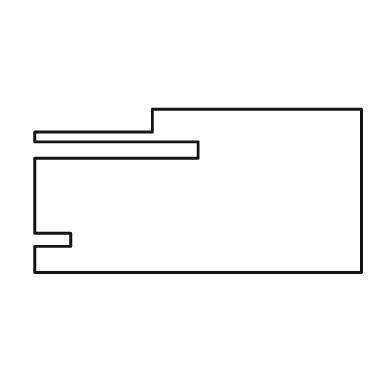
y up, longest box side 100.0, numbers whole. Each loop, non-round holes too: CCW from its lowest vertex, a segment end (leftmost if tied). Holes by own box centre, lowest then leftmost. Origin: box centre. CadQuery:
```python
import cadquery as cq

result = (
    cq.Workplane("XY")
    .moveTo(-50.0, -25.0)
    .lineTo(50.0, -25.0)
    .lineTo(50.0, 25.0)
    .lineTo(-14.0, 25.0)
    .lineTo(-14.0, 18.0)
    .lineTo(-50.0, 18.0)
    .lineTo(-50.0, 15.0)
    .lineTo(0.0, 15.0)
    .lineTo(0.0, 10.0)
    .lineTo(-50.0, 10.0)
    .lineTo(-50.0, -13.0)
    .lineTo(-39.0, -13.0)
    .lineTo(-39.0, -17.0)
    .lineTo(-50.0, -17.0)
    .close()
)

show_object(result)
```